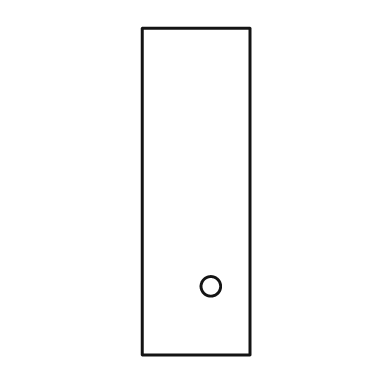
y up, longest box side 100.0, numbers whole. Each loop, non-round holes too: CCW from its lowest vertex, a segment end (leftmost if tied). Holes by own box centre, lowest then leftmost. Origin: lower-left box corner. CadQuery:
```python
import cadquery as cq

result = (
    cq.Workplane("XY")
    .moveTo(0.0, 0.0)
    .lineTo(33.0, 0.0)
    .lineTo(33.0, 100.0)
    .lineTo(0.0, 100.0)
    .close()
    .moveTo(21.0, 21.0)
    .circle(3.0)
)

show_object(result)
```